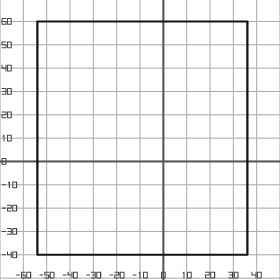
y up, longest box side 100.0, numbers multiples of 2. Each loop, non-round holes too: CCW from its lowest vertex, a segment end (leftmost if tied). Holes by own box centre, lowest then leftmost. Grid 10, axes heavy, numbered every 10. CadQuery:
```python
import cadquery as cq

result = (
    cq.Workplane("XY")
    .moveTo(-54.0, -40.0)
    .lineTo(36.0, -40.0)
    .lineTo(36.0, 60.0)
    .lineTo(-54.0, 60.0)
    .close()
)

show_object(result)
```